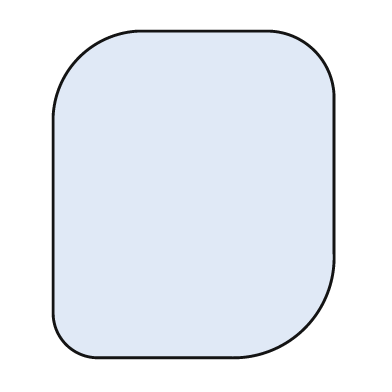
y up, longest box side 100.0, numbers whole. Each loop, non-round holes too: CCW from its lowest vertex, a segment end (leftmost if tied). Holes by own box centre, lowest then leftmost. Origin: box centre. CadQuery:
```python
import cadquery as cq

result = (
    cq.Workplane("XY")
    .moveTo(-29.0, -50.0)
    .lineTo(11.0, -50.0)
    .threePointArc((34.0, -41.0), (43.0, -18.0))
    .lineTo(43.0, 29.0)
    .threePointArc((37.0, 44.0), (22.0, 50.0))
    .lineTo(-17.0, 50.0)
    .threePointArc((-35.0, 42.0), (-43.0, 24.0))
    .lineTo(-43.0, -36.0)
    .threePointArc((-39.0, -46.0), (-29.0, -50.0))
    .close()
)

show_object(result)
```